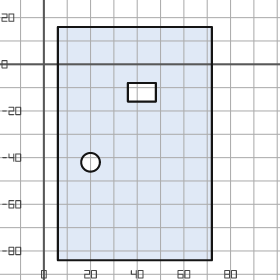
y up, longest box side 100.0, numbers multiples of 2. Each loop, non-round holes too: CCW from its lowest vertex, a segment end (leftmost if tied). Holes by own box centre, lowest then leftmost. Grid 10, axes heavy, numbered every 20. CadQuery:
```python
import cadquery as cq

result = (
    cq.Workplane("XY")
    .moveTo(6.0, -84.0)
    .lineTo(72.0, -84.0)
    .lineTo(72.0, 16.0)
    .lineTo(6.0, 16.0)
    .close()
    .moveTo(20.0, -42.0)
    .circle(4.0)
    .moveTo(36.0, -16.0)
    .lineTo(48.0, -16.0)
    .lineTo(48.0, -8.0)
    .lineTo(36.0, -8.0)
    .close()
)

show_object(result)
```